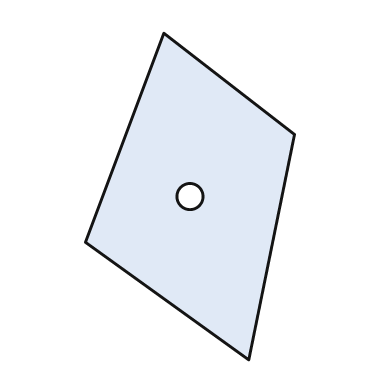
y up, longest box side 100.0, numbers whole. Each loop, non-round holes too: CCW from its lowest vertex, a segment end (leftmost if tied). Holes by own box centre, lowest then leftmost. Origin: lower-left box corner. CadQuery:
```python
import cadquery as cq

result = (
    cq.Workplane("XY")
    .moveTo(50.0, 0.0)
    .lineTo(64.0, 69.0)
    .lineTo(24.0, 100.0)
    .lineTo(0.0, 36.0)
    .close()
    .moveTo(32.0, 50.0)
    .circle(4.0)
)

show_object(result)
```